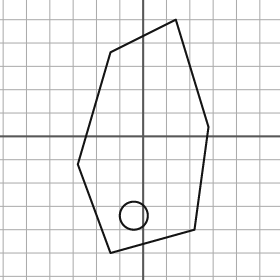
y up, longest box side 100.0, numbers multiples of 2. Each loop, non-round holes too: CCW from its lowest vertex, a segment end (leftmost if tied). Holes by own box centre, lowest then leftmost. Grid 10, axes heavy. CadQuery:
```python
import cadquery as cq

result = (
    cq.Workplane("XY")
    .moveTo(-14.0, -50.0)
    .lineTo(22.0, -40.0)
    .lineTo(28.0, 4.0)
    .lineTo(14.0, 50.0)
    .lineTo(-14.0, 36.0)
    .lineTo(-28.0, -12.0)
    .close()
    .moveTo(-4.0, -34.0)
    .circle(6.0)
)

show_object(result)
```